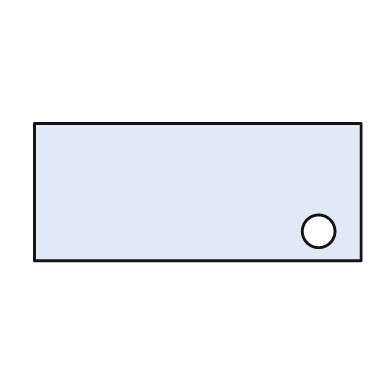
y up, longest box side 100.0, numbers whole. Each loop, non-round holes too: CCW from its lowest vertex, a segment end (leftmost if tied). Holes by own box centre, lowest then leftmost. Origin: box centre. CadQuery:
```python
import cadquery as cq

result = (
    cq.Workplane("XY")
    .moveTo(-50.0, -21.0)
    .lineTo(50.0, -21.0)
    .lineTo(50.0, 21.0)
    .lineTo(-50.0, 21.0)
    .close()
    .moveTo(37.0, -12.0)
    .circle(5.0)
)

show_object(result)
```